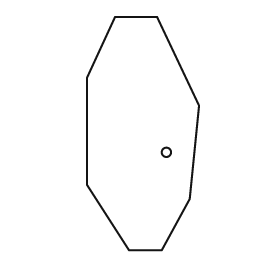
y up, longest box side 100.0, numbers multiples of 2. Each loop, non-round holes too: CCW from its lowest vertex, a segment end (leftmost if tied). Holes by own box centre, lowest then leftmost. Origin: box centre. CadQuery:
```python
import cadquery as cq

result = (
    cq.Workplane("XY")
    .moveTo(-6.0, -50.0)
    .lineTo(8.0, -50.0)
    .lineTo(20.0, -28.0)
    .lineTo(24.0, 12.0)
    .lineTo(6.0, 50.0)
    .lineTo(-12.0, 50.0)
    .lineTo(-24.0, 24.0)
    .lineTo(-24.0, -22.0)
    .close()
    .moveTo(10.0, -8.0)
    .circle(2.0)
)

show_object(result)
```